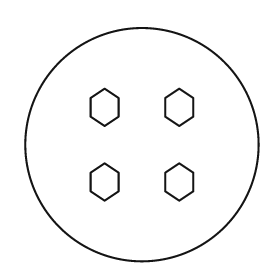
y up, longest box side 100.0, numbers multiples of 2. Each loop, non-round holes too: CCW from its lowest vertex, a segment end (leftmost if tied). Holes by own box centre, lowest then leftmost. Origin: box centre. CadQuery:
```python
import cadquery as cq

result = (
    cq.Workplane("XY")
    .moveTo(0.0, 0.0)
    .circle(50.0)
    .moveTo(-16.0, -24.0)
    .lineTo(-10.0, -20.0)
    .lineTo(-10.0, -12.0)
    .lineTo(-16.0, -8.0)
    .lineTo(-22.0, -12.0)
    .lineTo(-22.0, -20.0)
    .close()
    .moveTo(16.0, -24.0)
    .lineTo(22.0, -20.0)
    .lineTo(22.0, -12.0)
    .lineTo(16.0, -8.0)
    .lineTo(10.0, -12.0)
    .lineTo(10.0, -20.0)
    .close()
    .moveTo(-16.0, 8.0)
    .lineTo(-10.0, 12.0)
    .lineTo(-10.0, 20.0)
    .lineTo(-16.0, 24.0)
    .lineTo(-22.0, 20.0)
    .lineTo(-22.0, 12.0)
    .close()
    .moveTo(16.0, 8.0)
    .lineTo(22.0, 12.0)
    .lineTo(22.0, 20.0)
    .lineTo(16.0, 24.0)
    .lineTo(10.0, 20.0)
    .lineTo(10.0, 12.0)
    .close()
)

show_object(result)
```